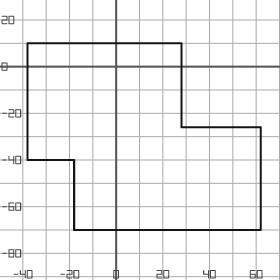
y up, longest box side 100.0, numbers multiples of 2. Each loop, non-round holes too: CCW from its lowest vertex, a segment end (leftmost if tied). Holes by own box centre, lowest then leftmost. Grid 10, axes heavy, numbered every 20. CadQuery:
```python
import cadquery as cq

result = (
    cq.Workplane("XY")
    .moveTo(-18.0, -70.0)
    .lineTo(62.0, -70.0)
    .lineTo(62.0, -26.0)
    .lineTo(28.0, -26.0)
    .lineTo(28.0, 10.0)
    .lineTo(-38.0, 10.0)
    .lineTo(-38.0, -40.0)
    .lineTo(-18.0, -40.0)
    .close()
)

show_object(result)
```